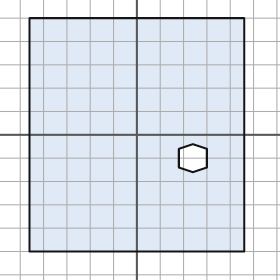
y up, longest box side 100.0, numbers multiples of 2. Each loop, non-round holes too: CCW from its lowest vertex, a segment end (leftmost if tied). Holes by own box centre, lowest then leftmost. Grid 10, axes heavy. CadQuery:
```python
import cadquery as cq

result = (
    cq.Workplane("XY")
    .moveTo(-46.0, -50.0)
    .lineTo(46.0, -50.0)
    .lineTo(46.0, 50.0)
    .lineTo(-46.0, 50.0)
    .close()
    .moveTo(24.0, -16.0)
    .lineTo(30.0, -14.0)
    .lineTo(30.0, -6.0)
    .lineTo(24.0, -4.0)
    .lineTo(18.0, -6.0)
    .lineTo(18.0, -14.0)
    .close()
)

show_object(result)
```